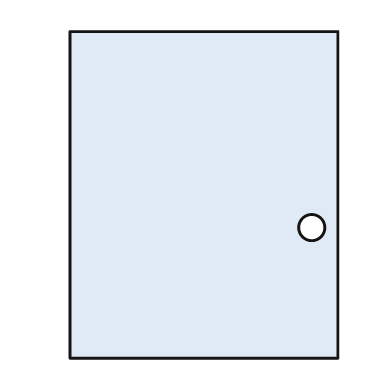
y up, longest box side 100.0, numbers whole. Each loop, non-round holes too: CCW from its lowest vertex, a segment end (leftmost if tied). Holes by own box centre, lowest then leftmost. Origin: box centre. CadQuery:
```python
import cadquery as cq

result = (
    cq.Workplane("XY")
    .moveTo(-41.0, -50.0)
    .lineTo(41.0, -50.0)
    .lineTo(41.0, 50.0)
    .lineTo(-41.0, 50.0)
    .close()
    .moveTo(33.0, -10.0)
    .circle(4.0)
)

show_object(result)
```